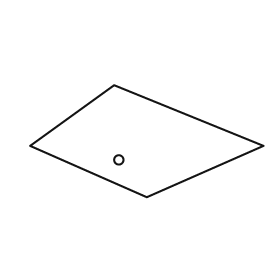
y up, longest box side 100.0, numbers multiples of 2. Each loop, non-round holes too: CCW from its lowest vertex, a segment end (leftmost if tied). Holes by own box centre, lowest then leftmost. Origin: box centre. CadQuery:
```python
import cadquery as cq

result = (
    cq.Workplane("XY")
    .moveTo(0.0, -24.0)
    .lineTo(50.0, -2.0)
    .lineTo(-14.0, 24.0)
    .lineTo(-50.0, -2.0)
    .close()
    .moveTo(-12.0, -8.0)
    .circle(2.0)
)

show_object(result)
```